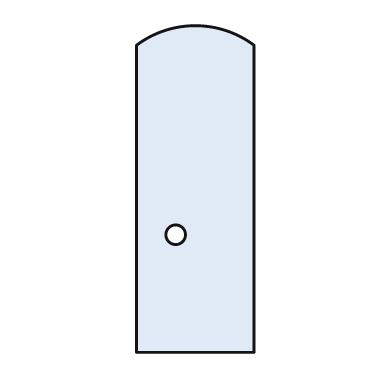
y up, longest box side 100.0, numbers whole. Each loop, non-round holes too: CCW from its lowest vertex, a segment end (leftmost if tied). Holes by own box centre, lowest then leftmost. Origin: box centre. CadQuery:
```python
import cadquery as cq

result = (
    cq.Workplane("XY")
    .moveTo(-18.0, -50.0)
    .lineTo(18.0, -50.0)
    .lineTo(18.0, 44.0)
    .threePointArc((0.0, 50.0), (-18.0, 44.0))
    .close()
    .moveTo(-6.0, -14.0)
    .circle(3.0)
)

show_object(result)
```